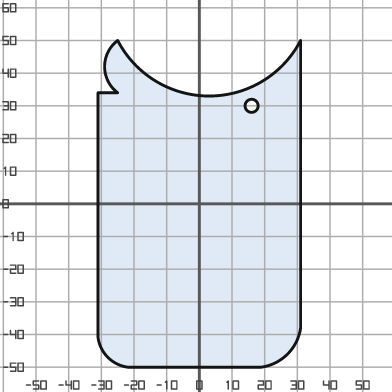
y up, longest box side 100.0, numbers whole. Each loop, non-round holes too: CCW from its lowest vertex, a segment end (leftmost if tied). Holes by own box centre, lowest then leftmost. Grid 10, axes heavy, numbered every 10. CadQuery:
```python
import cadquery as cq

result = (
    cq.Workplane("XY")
    .moveTo(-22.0, -50.0)
    .lineTo(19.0, -50.0)
    .threePointArc((27.0, -46.0), (31.0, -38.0))
    .lineTo(31.0, 50.0)
    .threePointArc((3.0, 33.0), (-25.0, 50.0))
    .threePointArc((-29.0, 42.0), (-25.0, 34.0))
    .lineTo(-31.0, 34.0)
    .lineTo(-31.0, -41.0)
    .threePointArc((-28.0, -47.0), (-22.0, -50.0))
    .close()
    .moveTo(16.0, 30.0)
    .circle(2.0)
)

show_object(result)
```